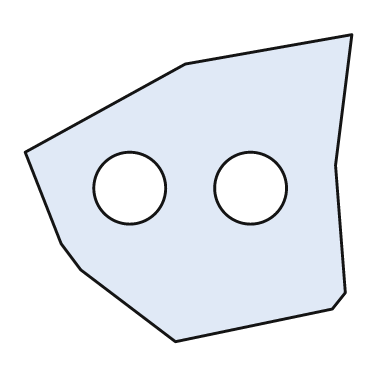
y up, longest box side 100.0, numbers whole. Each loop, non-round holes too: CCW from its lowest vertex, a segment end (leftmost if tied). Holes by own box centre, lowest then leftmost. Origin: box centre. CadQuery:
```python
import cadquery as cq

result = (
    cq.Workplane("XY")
    .moveTo(-4.0, -47.0)
    .lineTo(44.0, -37.0)
    .lineTo(48.0, -32.0)
    .lineTo(45.0, 7.0)
    .lineTo(50.0, 47.0)
    .lineTo(-1.0, 38.0)
    .lineTo(-50.0, 11.0)
    .lineTo(-39.0, -17.0)
    .lineTo(-33.0, -25.0)
    .close()
    .moveTo(-18.0, 0.0)
    .circle(11.0)
    .moveTo(19.0, 0.0)
    .circle(11.0)
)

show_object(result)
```